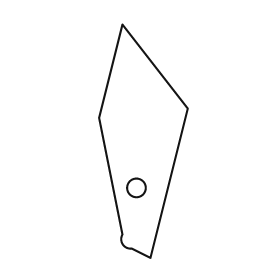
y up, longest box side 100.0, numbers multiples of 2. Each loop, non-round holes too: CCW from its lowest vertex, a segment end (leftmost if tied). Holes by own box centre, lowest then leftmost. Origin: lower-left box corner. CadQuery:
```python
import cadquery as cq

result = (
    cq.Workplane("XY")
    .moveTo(22.0, 0.0)
    .lineTo(38.0, 64.0)
    .lineTo(10.0, 100.0)
    .lineTo(0.0, 60.0)
    .lineTo(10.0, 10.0)
    .threePointArc((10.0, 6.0), (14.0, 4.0))
    .close()
    .moveTo(16.0, 30.0)
    .circle(4.0)
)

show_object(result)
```